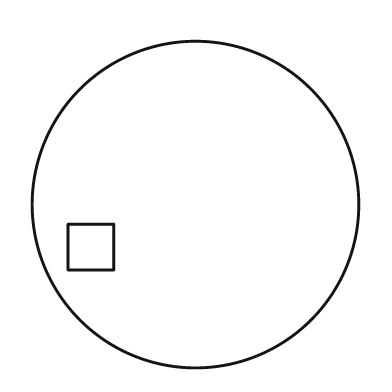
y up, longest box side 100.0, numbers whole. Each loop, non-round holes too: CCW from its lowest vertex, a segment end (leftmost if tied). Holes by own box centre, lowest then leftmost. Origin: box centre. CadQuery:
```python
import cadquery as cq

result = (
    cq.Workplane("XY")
    .moveTo(0.0, 0.0)
    .circle(50.0)
    .moveTo(-39.0, -20.0)
    .lineTo(-25.0, -20.0)
    .lineTo(-25.0, -6.0)
    .lineTo(-39.0, -6.0)
    .close()
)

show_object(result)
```